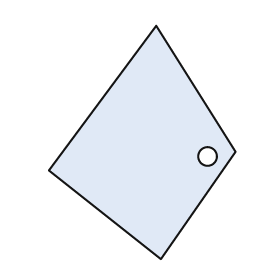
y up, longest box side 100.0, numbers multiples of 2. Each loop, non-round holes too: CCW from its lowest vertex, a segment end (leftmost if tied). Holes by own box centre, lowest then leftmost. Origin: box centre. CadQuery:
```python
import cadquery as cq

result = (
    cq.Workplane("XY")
    .moveTo(8.0, -50.0)
    .lineTo(40.0, -4.0)
    .lineTo(6.0, 50.0)
    .lineTo(-40.0, -12.0)
    .close()
    .moveTo(28.0, -6.0)
    .circle(4.0)
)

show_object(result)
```